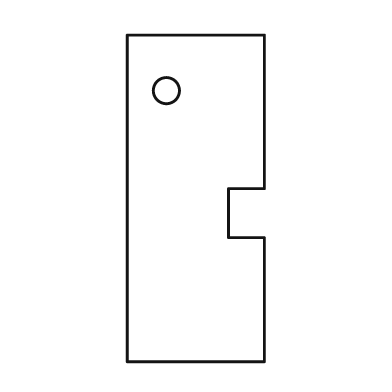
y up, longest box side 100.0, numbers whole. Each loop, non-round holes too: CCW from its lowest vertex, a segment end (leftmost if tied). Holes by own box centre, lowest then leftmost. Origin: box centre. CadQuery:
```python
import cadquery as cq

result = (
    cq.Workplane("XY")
    .moveTo(-21.0, -50.0)
    .lineTo(21.0, -50.0)
    .lineTo(21.0, -12.0)
    .lineTo(10.0, -12.0)
    .lineTo(10.0, 3.0)
    .lineTo(21.0, 3.0)
    .lineTo(21.0, 50.0)
    .lineTo(-21.0, 50.0)
    .close()
    .moveTo(-9.0, 33.0)
    .circle(4.0)
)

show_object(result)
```